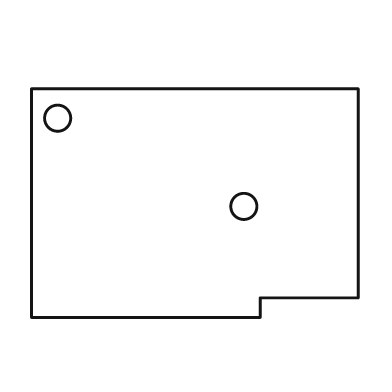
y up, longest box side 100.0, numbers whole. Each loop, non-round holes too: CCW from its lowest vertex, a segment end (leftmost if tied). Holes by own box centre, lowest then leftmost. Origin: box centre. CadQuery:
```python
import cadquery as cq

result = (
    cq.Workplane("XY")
    .moveTo(-50.0, -35.0)
    .lineTo(20.0, -35.0)
    .lineTo(20.0, -29.0)
    .lineTo(50.0, -29.0)
    .lineTo(50.0, 35.0)
    .lineTo(-50.0, 35.0)
    .close()
    .moveTo(15.0, -1.0)
    .circle(4.0)
    .moveTo(-42.0, 26.0)
    .circle(4.0)
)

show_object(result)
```